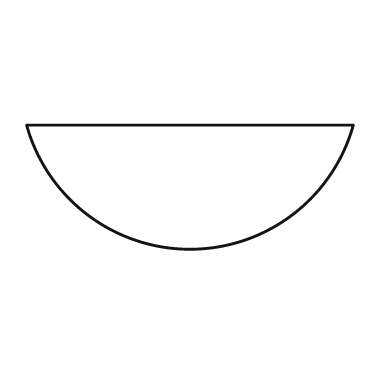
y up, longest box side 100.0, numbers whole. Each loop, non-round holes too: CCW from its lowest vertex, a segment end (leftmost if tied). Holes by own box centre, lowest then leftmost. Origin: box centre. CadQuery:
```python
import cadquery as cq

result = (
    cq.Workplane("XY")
    .moveTo(-50.0, 19.0)
    .threePointArc((0.0, -19.0), (50.0, 19.0))
    .close()
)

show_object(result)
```